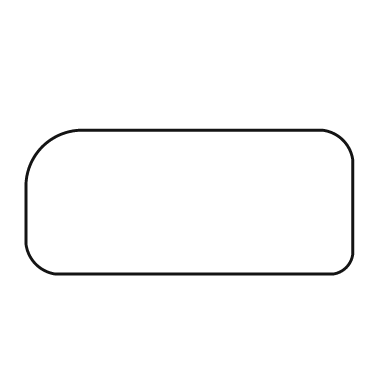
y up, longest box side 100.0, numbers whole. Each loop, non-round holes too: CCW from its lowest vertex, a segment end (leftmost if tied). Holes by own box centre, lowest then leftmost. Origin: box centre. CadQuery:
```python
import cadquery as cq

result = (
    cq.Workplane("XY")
    .moveTo(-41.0, -22.0)
    .lineTo(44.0, -22.0)
    .threePointArc((48.0, -20.0), (50.0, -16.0))
    .lineTo(50.0, 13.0)
    .threePointArc((47.0, 19.0), (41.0, 22.0))
    .lineTo(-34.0, 22.0)
    .threePointArc((-45.0, 17.0), (-50.0, 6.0))
    .lineTo(-50.0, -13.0)
    .threePointArc((-47.0, -19.0), (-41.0, -22.0))
    .close()
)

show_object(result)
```